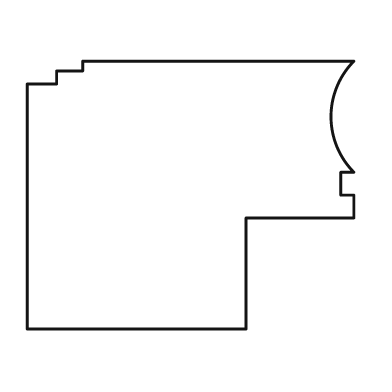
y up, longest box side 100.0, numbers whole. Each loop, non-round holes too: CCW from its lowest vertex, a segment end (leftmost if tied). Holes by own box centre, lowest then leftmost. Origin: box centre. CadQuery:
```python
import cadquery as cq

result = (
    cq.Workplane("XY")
    .moveTo(-50.0, -41.0)
    .lineTo(17.0, -41.0)
    .lineTo(17.0, -7.0)
    .lineTo(50.0, -7.0)
    .lineTo(50.0, 0.0)
    .lineTo(46.0, 0.0)
    .lineTo(46.0, 7.0)
    .lineTo(50.0, 7.0)
    .threePointArc((43.0, 24.0), (50.0, 41.0))
    .lineTo(-33.0, 41.0)
    .lineTo(-33.0, 38.0)
    .lineTo(-41.0, 38.0)
    .lineTo(-41.0, 34.0)
    .lineTo(-50.0, 34.0)
    .close()
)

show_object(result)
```